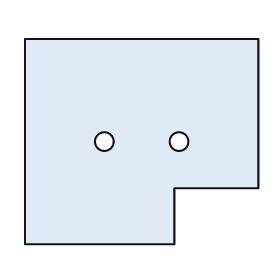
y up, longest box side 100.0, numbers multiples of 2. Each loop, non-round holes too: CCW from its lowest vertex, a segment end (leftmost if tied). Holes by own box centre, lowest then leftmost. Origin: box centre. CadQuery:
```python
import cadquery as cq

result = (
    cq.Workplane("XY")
    .moveTo(-50.0, -44.0)
    .lineTo(14.0, -44.0)
    .lineTo(14.0, -20.0)
    .lineTo(50.0, -20.0)
    .lineTo(50.0, 44.0)
    .lineTo(-50.0, 44.0)
    .close()
    .moveTo(-16.0, 0.0)
    .circle(4.0)
    .moveTo(16.0, 0.0)
    .circle(4.0)
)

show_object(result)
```